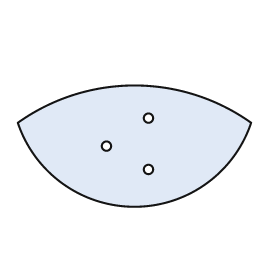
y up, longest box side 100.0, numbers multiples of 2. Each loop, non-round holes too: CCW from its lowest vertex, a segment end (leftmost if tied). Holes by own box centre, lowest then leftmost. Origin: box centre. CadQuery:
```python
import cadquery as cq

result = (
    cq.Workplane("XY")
    .moveTo(-50.0, 10.0)
    .threePointArc((0.0, -26.0), (50.0, 10.0))
    .threePointArc((0.0, 26.0), (-50.0, 10.0))
    .close()
    .moveTo(6.0, -10.0)
    .circle(2.0)
    .moveTo(-12.0, 0.0)
    .circle(2.0)
    .moveTo(6.0, 12.0)
    .circle(2.0)
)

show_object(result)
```